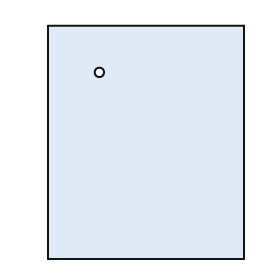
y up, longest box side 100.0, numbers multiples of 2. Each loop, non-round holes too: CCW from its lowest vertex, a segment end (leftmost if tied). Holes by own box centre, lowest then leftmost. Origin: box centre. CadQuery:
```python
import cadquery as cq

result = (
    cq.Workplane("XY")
    .moveTo(-42.0, -50.0)
    .lineTo(42.0, -50.0)
    .lineTo(42.0, 50.0)
    .lineTo(-42.0, 50.0)
    .close()
    .moveTo(-20.0, 30.0)
    .circle(2.0)
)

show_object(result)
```